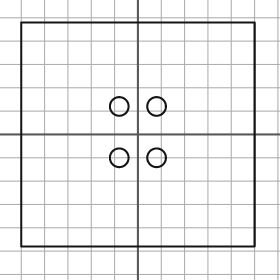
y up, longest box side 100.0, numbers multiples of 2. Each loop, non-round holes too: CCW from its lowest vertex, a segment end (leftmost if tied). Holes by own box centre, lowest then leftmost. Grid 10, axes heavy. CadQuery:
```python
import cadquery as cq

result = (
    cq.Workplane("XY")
    .moveTo(-50.0, -48.0)
    .lineTo(50.0, -48.0)
    .lineTo(50.0, 48.0)
    .lineTo(-50.0, 48.0)
    .close()
    .moveTo(-8.0, -10.0)
    .circle(4.0)
    .moveTo(8.0, -10.0)
    .circle(4.0)
    .moveTo(-8.0, 12.0)
    .circle(4.0)
    .moveTo(8.0, 12.0)
    .circle(4.0)
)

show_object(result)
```